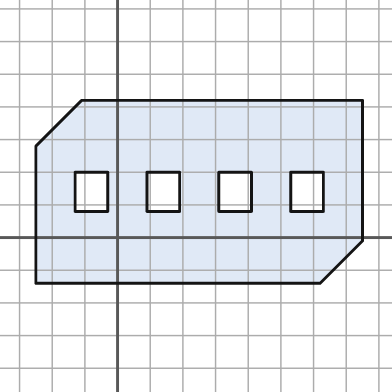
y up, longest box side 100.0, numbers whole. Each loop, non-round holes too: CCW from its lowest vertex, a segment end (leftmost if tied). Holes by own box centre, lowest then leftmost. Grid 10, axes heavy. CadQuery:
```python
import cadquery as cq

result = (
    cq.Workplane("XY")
    .moveTo(-25.0, -14.0)
    .lineTo(62.0, -14.0)
    .lineTo(75.0, -1.0)
    .lineTo(75.0, 42.0)
    .lineTo(-11.0, 42.0)
    .lineTo(-25.0, 28.0)
    .close()
    .moveTo(-13.0, 8.0)
    .lineTo(-3.0, 8.0)
    .lineTo(-3.0, 20.0)
    .lineTo(-13.0, 20.0)
    .close()
    .moveTo(9.0, 8.0)
    .lineTo(19.0, 8.0)
    .lineTo(19.0, 20.0)
    .lineTo(9.0, 20.0)
    .close()
    .moveTo(31.0, 8.0)
    .lineTo(41.0, 8.0)
    .lineTo(41.0, 20.0)
    .lineTo(31.0, 20.0)
    .close()
    .moveTo(53.0, 8.0)
    .lineTo(63.0, 8.0)
    .lineTo(63.0, 20.0)
    .lineTo(53.0, 20.0)
    .close()
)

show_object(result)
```